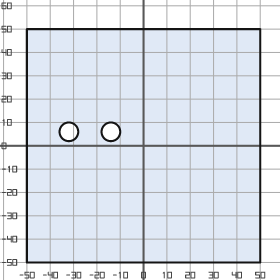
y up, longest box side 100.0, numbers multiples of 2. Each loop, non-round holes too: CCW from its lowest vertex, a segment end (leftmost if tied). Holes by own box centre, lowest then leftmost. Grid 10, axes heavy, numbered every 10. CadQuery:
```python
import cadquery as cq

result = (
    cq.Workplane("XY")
    .moveTo(-50.0, -50.0)
    .lineTo(50.0, -50.0)
    .lineTo(50.0, 50.0)
    .lineTo(-50.0, 50.0)
    .close()
    .moveTo(-32.0, 6.0)
    .circle(4.0)
    .moveTo(-14.0, 6.0)
    .circle(4.0)
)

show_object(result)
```